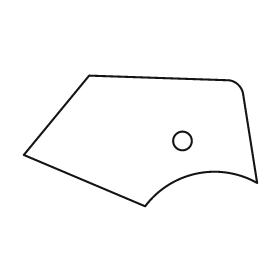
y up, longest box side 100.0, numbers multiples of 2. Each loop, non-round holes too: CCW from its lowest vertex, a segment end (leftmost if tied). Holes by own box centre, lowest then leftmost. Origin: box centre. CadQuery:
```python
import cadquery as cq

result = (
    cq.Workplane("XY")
    .moveTo(2.0, -28.0)
    .threePointArc((24.0, -14.0), (50.0, -18.0))
    .lineTo(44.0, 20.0)
    .threePointArc((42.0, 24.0), (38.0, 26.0))
    .lineTo(-22.0, 28.0)
    .lineTo(-50.0, -6.0)
    .close()
    .moveTo(18.0, 0.0)
    .circle(4.0)
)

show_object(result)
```